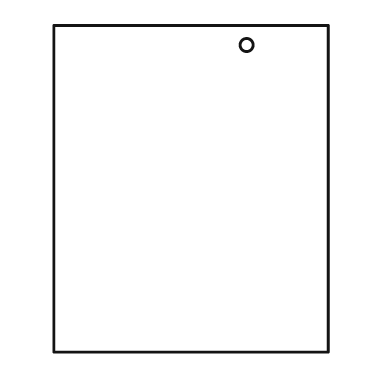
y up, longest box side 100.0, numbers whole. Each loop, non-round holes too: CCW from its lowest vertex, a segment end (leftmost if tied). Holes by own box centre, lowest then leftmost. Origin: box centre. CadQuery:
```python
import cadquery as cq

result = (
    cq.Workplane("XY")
    .moveTo(-42.0, -50.0)
    .lineTo(42.0, -50.0)
    .lineTo(42.0, 50.0)
    .lineTo(-42.0, 50.0)
    .close()
    .moveTo(17.0, 44.0)
    .circle(2.0)
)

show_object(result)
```